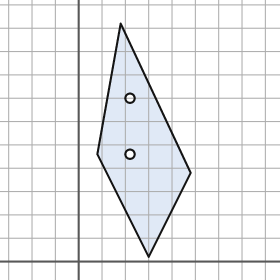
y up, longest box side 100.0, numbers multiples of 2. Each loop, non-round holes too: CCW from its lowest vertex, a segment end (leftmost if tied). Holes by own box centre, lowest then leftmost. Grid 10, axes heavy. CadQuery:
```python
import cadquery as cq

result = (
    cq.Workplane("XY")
    .moveTo(30.0, 2.0)
    .lineTo(48.0, 38.0)
    .lineTo(18.0, 102.0)
    .lineTo(8.0, 46.0)
    .close()
    .moveTo(22.0, 46.0)
    .circle(2.0)
    .moveTo(22.0, 70.0)
    .circle(2.0)
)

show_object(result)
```